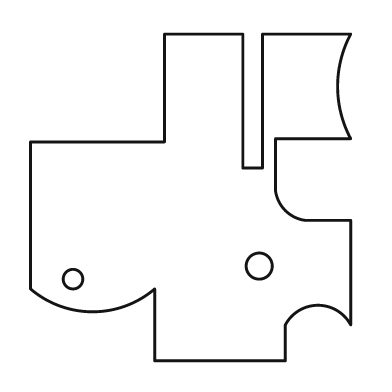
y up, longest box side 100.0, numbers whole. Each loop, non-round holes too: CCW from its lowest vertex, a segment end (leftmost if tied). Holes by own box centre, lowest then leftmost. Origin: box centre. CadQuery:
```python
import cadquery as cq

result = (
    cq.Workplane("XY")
    .moveTo(-11.0, -50.0)
    .lineTo(29.0, -50.0)
    .lineTo(29.0, -39.0)
    .threePointArc((39.0, -33.0), (49.0, -39.0))
    .lineTo(49.0, -7.0)
    .lineTo(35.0, -7.0)
    .threePointArc((29.0, -4.0), (26.0, 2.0))
    .lineTo(26.0, 18.0)
    .lineTo(49.0, 18.0)
    .threePointArc((45.0, 34.0), (49.0, 50.0))
    .lineTo(22.0, 50.0)
    .lineTo(22.0, 9.0)
    .lineTo(16.0, 9.0)
    .lineTo(16.0, 50.0)
    .lineTo(-8.0, 50.0)
    .lineTo(-8.0, 17.0)
    .lineTo(-49.0, 17.0)
    .lineTo(-49.0, -28.0)
    .threePointArc((-30.0, -35.0), (-11.0, -28.0))
    .close()
    .moveTo(-36.0, -25.0)
    .circle(3.0)
    .moveTo(21.0, -21.0)
    .circle(4.0)
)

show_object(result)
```